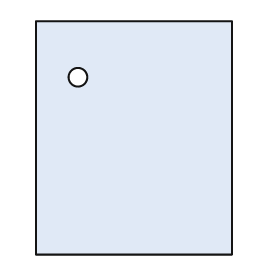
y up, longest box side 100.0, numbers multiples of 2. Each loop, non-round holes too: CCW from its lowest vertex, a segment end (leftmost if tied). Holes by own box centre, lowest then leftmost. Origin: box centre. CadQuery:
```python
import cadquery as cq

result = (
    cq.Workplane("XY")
    .moveTo(-42.0, -50.0)
    .lineTo(42.0, -50.0)
    .lineTo(42.0, 50.0)
    .lineTo(-42.0, 50.0)
    .close()
    .moveTo(-24.0, 26.0)
    .circle(4.0)
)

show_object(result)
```